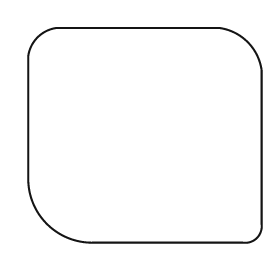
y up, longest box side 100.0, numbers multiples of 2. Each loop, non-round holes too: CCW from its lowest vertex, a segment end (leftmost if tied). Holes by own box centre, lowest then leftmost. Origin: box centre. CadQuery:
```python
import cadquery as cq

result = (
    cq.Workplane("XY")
    .moveTo(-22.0, -46.0)
    .lineTo(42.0, -46.0)
    .threePointArc((48.0, -44.0), (50.0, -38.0))
    .lineTo(50.0, 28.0)
    .threePointArc((44.0, 40.0), (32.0, 46.0))
    .lineTo(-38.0, 46.0)
    .threePointArc((-46.0, 42.0), (-50.0, 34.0))
    .lineTo(-50.0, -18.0)
    .threePointArc((-42.0, -38.0), (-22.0, -46.0))
    .close()
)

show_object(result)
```